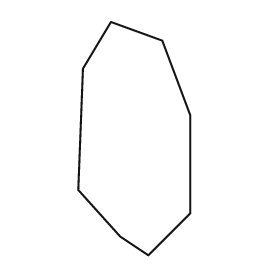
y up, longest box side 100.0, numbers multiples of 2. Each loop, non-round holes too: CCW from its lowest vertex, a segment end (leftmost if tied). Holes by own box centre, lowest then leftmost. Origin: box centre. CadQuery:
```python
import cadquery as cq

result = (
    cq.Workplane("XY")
    .moveTo(6.0, -50.0)
    .lineTo(24.0, -32.0)
    .lineTo(24.0, 10.0)
    .lineTo(12.0, 42.0)
    .lineTo(-10.0, 50.0)
    .lineTo(-22.0, 30.0)
    .lineTo(-24.0, -22.0)
    .lineTo(-6.0, -42.0)
    .close()
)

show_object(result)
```